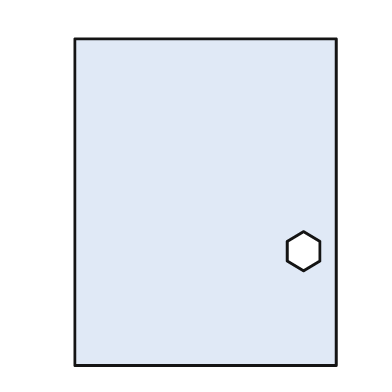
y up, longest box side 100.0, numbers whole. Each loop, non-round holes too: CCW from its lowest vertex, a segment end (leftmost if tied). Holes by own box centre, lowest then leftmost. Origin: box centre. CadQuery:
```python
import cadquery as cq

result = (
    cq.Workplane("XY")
    .moveTo(-40.0, -50.0)
    .lineTo(40.0, -50.0)
    .lineTo(40.0, 50.0)
    .lineTo(-40.0, 50.0)
    .close()
    .moveTo(30.0, -21.0)
    .lineTo(35.0, -18.0)
    .lineTo(35.0, -12.0)
    .lineTo(30.0, -9.0)
    .lineTo(25.0, -12.0)
    .lineTo(25.0, -18.0)
    .close()
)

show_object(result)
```